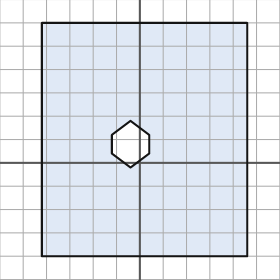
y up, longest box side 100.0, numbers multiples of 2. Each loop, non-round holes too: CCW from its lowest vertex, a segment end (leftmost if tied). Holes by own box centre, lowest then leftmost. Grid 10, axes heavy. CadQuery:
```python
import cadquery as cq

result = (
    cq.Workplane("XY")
    .moveTo(-42.0, -40.0)
    .lineTo(46.0, -40.0)
    .lineTo(46.0, 60.0)
    .lineTo(-42.0, 60.0)
    .close()
    .moveTo(-4.0, -2.0)
    .lineTo(4.0, 4.0)
    .lineTo(4.0, 12.0)
    .lineTo(-4.0, 18.0)
    .lineTo(-12.0, 12.0)
    .lineTo(-12.0, 4.0)
    .close()
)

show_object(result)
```